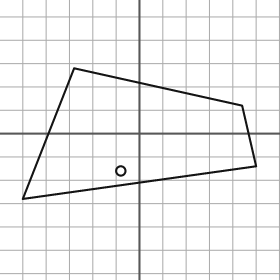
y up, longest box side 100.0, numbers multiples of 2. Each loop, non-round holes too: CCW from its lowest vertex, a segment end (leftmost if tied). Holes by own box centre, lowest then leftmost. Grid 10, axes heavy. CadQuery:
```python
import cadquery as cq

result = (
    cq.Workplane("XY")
    .moveTo(-50.0, -28.0)
    .lineTo(50.0, -14.0)
    .lineTo(44.0, 12.0)
    .lineTo(-28.0, 28.0)
    .close()
    .moveTo(-8.0, -16.0)
    .circle(2.0)
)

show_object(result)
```